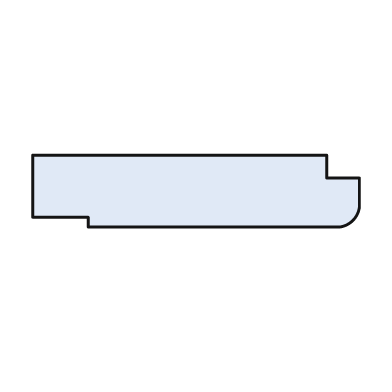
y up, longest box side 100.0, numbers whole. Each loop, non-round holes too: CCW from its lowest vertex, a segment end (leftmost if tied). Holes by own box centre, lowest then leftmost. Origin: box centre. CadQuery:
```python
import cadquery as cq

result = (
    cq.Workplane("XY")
    .moveTo(-33.0, -11.0)
    .lineTo(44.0, -11.0)
    .threePointArc((48.0, -9.0), (50.0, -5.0))
    .lineTo(50.0, 4.0)
    .lineTo(40.0, 4.0)
    .lineTo(40.0, 11.0)
    .lineTo(-50.0, 11.0)
    .lineTo(-50.0, -8.0)
    .lineTo(-33.0, -8.0)
    .close()
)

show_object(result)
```